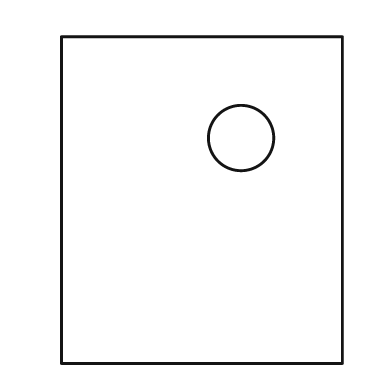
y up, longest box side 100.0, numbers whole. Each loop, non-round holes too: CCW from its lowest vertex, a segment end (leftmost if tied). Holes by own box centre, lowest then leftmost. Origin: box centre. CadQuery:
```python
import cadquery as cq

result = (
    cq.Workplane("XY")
    .moveTo(-43.0, -50.0)
    .lineTo(43.0, -50.0)
    .lineTo(43.0, 50.0)
    .lineTo(-43.0, 50.0)
    .close()
    .moveTo(12.0, 19.0)
    .circle(10.0)
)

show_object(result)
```